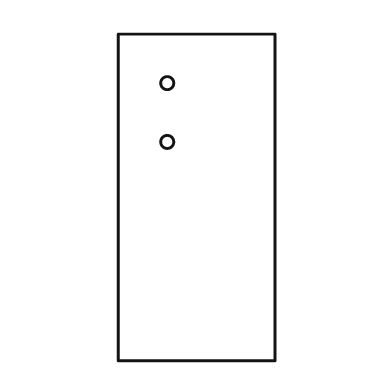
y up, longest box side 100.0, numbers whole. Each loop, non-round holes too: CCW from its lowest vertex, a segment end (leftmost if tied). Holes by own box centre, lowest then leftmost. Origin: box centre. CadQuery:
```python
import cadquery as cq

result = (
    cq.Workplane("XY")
    .moveTo(-24.0, -50.0)
    .lineTo(24.0, -50.0)
    .lineTo(24.0, 50.0)
    .lineTo(-24.0, 50.0)
    .close()
    .moveTo(-9.0, 17.0)
    .circle(2.0)
    .moveTo(-9.0, 35.0)
    .circle(2.0)
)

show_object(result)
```